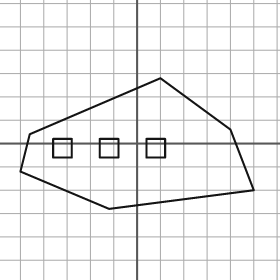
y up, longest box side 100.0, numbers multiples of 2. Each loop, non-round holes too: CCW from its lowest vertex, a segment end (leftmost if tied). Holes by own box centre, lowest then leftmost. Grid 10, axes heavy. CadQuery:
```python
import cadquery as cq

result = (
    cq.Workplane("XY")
    .moveTo(-12.0, -28.0)
    .lineTo(50.0, -20.0)
    .lineTo(40.0, 6.0)
    .lineTo(10.0, 28.0)
    .lineTo(-46.0, 4.0)
    .lineTo(-50.0, -12.0)
    .close()
    .moveTo(-36.0, -6.0)
    .lineTo(-28.0, -6.0)
    .lineTo(-28.0, 2.0)
    .lineTo(-36.0, 2.0)
    .close()
    .moveTo(-16.0, -6.0)
    .lineTo(-8.0, -6.0)
    .lineTo(-8.0, 2.0)
    .lineTo(-16.0, 2.0)
    .close()
    .moveTo(4.0, -6.0)
    .lineTo(12.0, -6.0)
    .lineTo(12.0, 2.0)
    .lineTo(4.0, 2.0)
    .close()
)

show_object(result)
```